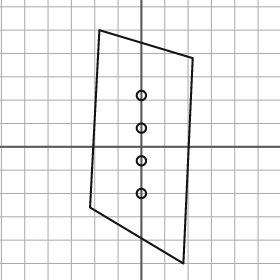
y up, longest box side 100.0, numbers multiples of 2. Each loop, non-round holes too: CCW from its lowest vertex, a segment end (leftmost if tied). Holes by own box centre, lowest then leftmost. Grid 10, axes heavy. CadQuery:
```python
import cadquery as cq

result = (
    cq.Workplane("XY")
    .moveTo(18.0, -50.0)
    .lineTo(22.0, 38.0)
    .lineTo(-18.0, 50.0)
    .lineTo(-22.0, -26.0)
    .close()
    .moveTo(0.0, -20.0)
    .circle(2.0)
    .moveTo(0.0, -6.0)
    .circle(2.0)
    .moveTo(0.0, 8.0)
    .circle(2.0)
    .moveTo(0.0, 22.0)
    .circle(2.0)
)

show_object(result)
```